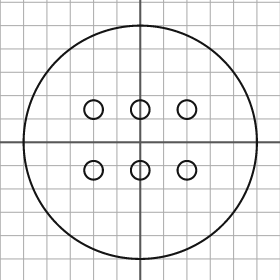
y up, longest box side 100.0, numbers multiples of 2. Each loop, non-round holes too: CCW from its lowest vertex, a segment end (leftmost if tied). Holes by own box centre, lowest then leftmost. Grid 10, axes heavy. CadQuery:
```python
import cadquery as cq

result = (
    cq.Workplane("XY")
    .moveTo(0.0, 0.0)
    .circle(50.0)
    .moveTo(-20.0, -12.0)
    .circle(4.0)
    .moveTo(0.0, -12.0)
    .circle(4.0)
    .moveTo(20.0, -12.0)
    .circle(4.0)
    .moveTo(-20.0, 14.0)
    .circle(4.0)
    .moveTo(0.0, 14.0)
    .circle(4.0)
    .moveTo(20.0, 14.0)
    .circle(4.0)
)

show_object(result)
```